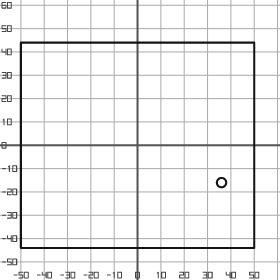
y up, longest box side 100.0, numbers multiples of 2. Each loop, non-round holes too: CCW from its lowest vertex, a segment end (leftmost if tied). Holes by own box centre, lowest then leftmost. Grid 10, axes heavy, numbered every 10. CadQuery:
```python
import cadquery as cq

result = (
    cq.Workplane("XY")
    .moveTo(-50.0, -44.0)
    .lineTo(50.0, -44.0)
    .lineTo(50.0, 44.0)
    .lineTo(-50.0, 44.0)
    .close()
    .moveTo(36.0, -16.0)
    .circle(2.0)
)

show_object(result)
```